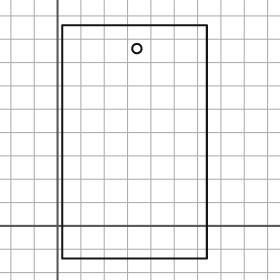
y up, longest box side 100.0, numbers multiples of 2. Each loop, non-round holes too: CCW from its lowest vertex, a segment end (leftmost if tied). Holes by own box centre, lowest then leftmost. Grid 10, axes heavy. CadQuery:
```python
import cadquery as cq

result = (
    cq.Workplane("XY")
    .moveTo(2.0, -14.0)
    .lineTo(64.0, -14.0)
    .lineTo(64.0, 86.0)
    .lineTo(2.0, 86.0)
    .close()
    .moveTo(34.0, 76.0)
    .circle(2.0)
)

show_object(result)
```